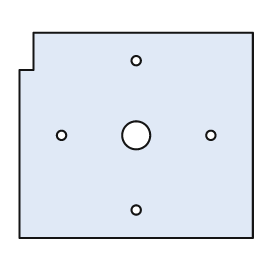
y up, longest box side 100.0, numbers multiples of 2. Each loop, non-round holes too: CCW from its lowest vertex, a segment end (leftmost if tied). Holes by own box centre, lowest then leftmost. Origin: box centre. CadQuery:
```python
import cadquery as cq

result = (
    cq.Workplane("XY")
    .moveTo(-50.0, -44.0)
    .lineTo(50.0, -44.0)
    .lineTo(50.0, 44.0)
    .lineTo(-44.0, 44.0)
    .lineTo(-44.0, 28.0)
    .lineTo(-50.0, 28.0)
    .close()
    .moveTo(0.0, -32.0)
    .circle(2.0)
    .moveTo(-32.0, 0.0)
    .circle(2.0)
    .moveTo(0.0, 0.0)
    .circle(6.0)
    .moveTo(32.0, 0.0)
    .circle(2.0)
    .moveTo(0.0, 32.0)
    .circle(2.0)
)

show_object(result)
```